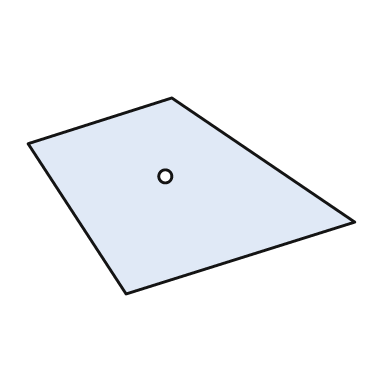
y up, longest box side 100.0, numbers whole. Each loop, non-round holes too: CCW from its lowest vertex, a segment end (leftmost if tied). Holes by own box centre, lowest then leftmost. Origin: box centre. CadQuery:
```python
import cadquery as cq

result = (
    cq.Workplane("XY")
    .moveTo(-20.0, -30.0)
    .lineTo(50.0, -8.0)
    .lineTo(-6.0, 30.0)
    .lineTo(-50.0, 16.0)
    .close()
    .moveTo(-8.0, 6.0)
    .circle(2.0)
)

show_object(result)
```